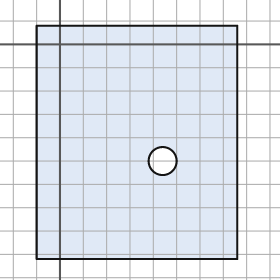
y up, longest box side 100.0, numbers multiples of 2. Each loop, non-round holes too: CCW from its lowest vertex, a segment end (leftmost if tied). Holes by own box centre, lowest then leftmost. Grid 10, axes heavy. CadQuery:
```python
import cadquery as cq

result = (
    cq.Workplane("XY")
    .moveTo(-10.0, -92.0)
    .lineTo(76.0, -92.0)
    .lineTo(76.0, 8.0)
    .lineTo(-10.0, 8.0)
    .close()
    .moveTo(44.0, -50.0)
    .circle(6.0)
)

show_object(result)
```